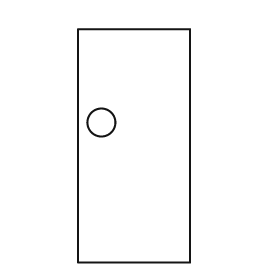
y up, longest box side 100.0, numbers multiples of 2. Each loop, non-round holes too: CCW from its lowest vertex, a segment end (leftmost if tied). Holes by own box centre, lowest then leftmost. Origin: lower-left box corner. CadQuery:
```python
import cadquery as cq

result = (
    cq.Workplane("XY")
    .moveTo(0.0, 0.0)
    .lineTo(48.0, 0.0)
    .lineTo(48.0, 100.0)
    .lineTo(0.0, 100.0)
    .close()
    .moveTo(10.0, 60.0)
    .circle(6.0)
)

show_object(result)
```